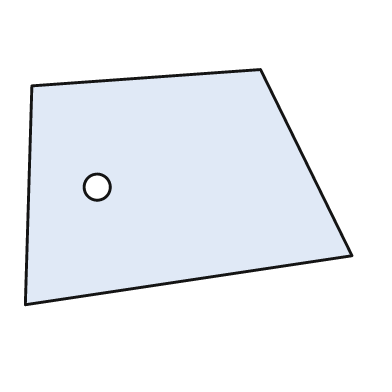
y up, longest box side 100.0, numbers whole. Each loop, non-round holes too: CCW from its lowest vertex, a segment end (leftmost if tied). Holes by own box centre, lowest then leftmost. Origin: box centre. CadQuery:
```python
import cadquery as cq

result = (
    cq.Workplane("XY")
    .moveTo(-50.0, -36.0)
    .lineTo(50.0, -21.0)
    .lineTo(22.0, 36.0)
    .lineTo(-48.0, 31.0)
    .close()
    .moveTo(-28.0, 0.0)
    .circle(4.0)
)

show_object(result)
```